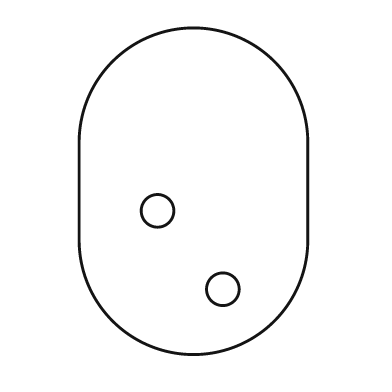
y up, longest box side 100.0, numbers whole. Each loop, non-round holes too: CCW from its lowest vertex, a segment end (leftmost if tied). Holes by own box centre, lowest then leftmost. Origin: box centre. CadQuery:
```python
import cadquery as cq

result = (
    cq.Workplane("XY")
    .moveTo(-35.0, -15.0)
    .threePointArc((0.0, -50.0), (35.0, -15.0))
    .lineTo(35.0, 15.0)
    .threePointArc((0.0, 50.0), (-35.0, 15.0))
    .close()
    .moveTo(9.0, -30.0)
    .circle(5.0)
    .moveTo(-11.0, -6.0)
    .circle(5.0)
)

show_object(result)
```